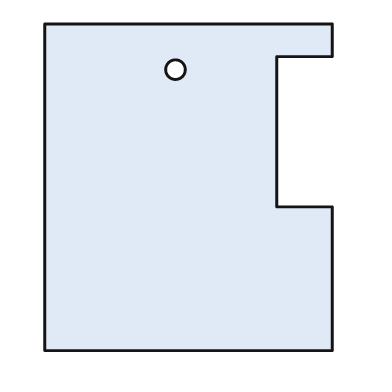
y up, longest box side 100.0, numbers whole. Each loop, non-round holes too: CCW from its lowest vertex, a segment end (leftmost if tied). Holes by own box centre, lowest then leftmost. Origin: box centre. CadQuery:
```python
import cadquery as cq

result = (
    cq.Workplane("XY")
    .moveTo(-44.0, -50.0)
    .lineTo(44.0, -50.0)
    .lineTo(44.0, -6.0)
    .lineTo(27.0, -6.0)
    .lineTo(27.0, 40.0)
    .lineTo(44.0, 40.0)
    .lineTo(44.0, 50.0)
    .lineTo(-44.0, 50.0)
    .close()
    .moveTo(-4.0, 36.0)
    .circle(3.0)
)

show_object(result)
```